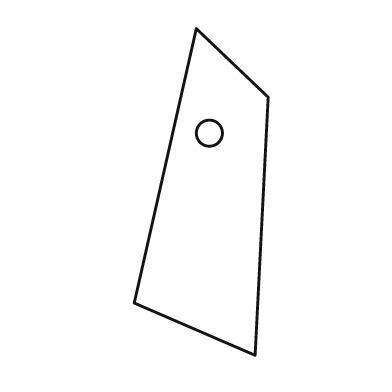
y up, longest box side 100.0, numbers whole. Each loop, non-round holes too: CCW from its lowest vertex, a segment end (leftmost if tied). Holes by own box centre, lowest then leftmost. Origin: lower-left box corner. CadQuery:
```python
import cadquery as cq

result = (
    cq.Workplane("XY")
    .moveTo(37.0, 0.0)
    .lineTo(41.0, 79.0)
    .lineTo(19.0, 100.0)
    .lineTo(0.0, 16.0)
    .close()
    .moveTo(23.0, 68.0)
    .circle(4.0)
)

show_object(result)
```